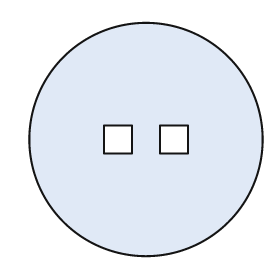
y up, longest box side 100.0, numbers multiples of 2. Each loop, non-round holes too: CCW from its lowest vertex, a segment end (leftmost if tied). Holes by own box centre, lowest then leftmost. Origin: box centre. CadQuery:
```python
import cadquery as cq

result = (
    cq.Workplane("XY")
    .moveTo(0.0, 0.0)
    .circle(50.0)
    .moveTo(-18.0, -6.0)
    .lineTo(-6.0, -6.0)
    .lineTo(-6.0, 6.0)
    .lineTo(-18.0, 6.0)
    .close()
    .moveTo(6.0, -6.0)
    .lineTo(18.0, -6.0)
    .lineTo(18.0, 6.0)
    .lineTo(6.0, 6.0)
    .close()
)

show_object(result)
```